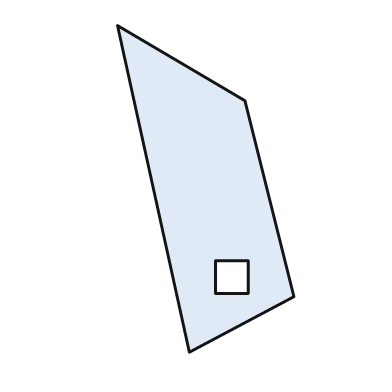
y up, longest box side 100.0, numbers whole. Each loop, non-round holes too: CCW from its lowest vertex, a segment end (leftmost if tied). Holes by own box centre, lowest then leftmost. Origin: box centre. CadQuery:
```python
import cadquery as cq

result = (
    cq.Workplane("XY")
    .moveTo(-5.0, -50.0)
    .lineTo(27.0, -33.0)
    .lineTo(12.0, 27.0)
    .lineTo(-27.0, 50.0)
    .close()
    .moveTo(3.0, -32.0)
    .lineTo(13.0, -32.0)
    .lineTo(13.0, -22.0)
    .lineTo(3.0, -22.0)
    .close()
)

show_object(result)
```